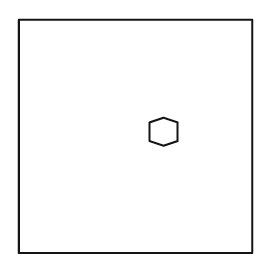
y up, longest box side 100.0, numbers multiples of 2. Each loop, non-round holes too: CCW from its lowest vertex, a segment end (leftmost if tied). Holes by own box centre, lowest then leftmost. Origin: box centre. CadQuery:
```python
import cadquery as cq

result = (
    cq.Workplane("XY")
    .moveTo(-50.0, -50.0)
    .lineTo(50.0, -50.0)
    .lineTo(50.0, 50.0)
    .lineTo(-50.0, 50.0)
    .close()
    .moveTo(12.0, -4.0)
    .lineTo(18.0, -2.0)
    .lineTo(18.0, 6.0)
    .lineTo(12.0, 8.0)
    .lineTo(6.0, 6.0)
    .lineTo(6.0, -2.0)
    .close()
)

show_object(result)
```